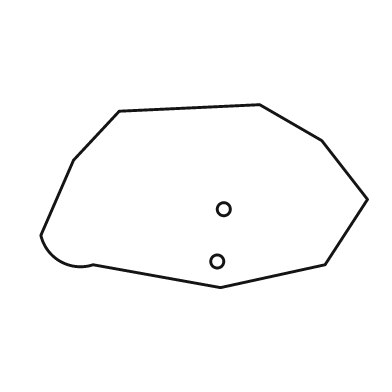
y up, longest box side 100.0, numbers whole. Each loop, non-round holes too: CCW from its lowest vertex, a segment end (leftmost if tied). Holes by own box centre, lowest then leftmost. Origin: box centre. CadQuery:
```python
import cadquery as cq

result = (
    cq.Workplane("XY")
    .moveTo(5.0, -28.0)
    .lineTo(37.0, -21.0)
    .lineTo(50.0, -1.0)
    .lineTo(36.0, 17.0)
    .lineTo(17.0, 28.0)
    .lineTo(-26.0, 26.0)
    .lineTo(-40.0, 11.0)
    .lineTo(-50.0, -12.0)
    .threePointArc((-44.0, -20.0), (-34.0, -21.0))
    .close()
    .moveTo(4.0, -20.0)
    .circle(2.0)
    .moveTo(6.0, -4.0)
    .circle(2.0)
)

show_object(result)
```